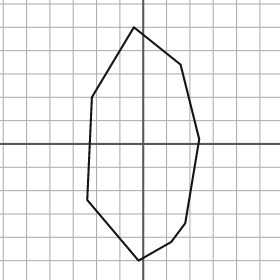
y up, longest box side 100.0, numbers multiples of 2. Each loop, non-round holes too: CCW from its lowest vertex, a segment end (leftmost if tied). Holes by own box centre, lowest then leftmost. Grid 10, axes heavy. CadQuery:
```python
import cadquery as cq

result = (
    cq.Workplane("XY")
    .moveTo(-2.0, -50.0)
    .lineTo(12.0, -42.0)
    .lineTo(18.0, -34.0)
    .lineTo(24.0, 2.0)
    .lineTo(16.0, 34.0)
    .lineTo(-4.0, 50.0)
    .lineTo(-22.0, 20.0)
    .lineTo(-24.0, -24.0)
    .close()
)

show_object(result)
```